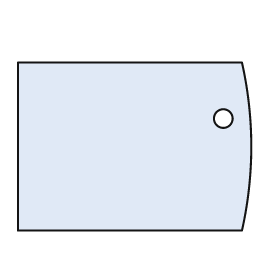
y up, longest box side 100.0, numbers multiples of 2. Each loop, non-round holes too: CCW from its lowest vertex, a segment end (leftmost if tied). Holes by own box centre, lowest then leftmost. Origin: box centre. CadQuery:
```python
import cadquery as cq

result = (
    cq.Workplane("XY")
    .moveTo(-50.0, -36.0)
    .lineTo(46.0, -36.0)
    .threePointArc((50.0, 0.0), (46.0, 36.0))
    .lineTo(-50.0, 36.0)
    .close()
    .moveTo(38.0, 12.0)
    .circle(4.0)
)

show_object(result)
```